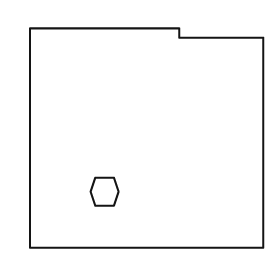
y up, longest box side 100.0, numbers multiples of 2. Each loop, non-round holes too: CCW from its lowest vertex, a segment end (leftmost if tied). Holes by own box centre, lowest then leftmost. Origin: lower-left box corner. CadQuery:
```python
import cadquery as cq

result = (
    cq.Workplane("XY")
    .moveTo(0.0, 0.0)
    .lineTo(100.0, 0.0)
    .lineTo(100.0, 90.0)
    .lineTo(64.0, 90.0)
    .lineTo(64.0, 94.0)
    .lineTo(0.0, 94.0)
    .close()
    .moveTo(28.0, 18.0)
    .lineTo(36.0, 18.0)
    .lineTo(38.0, 24.0)
    .lineTo(36.0, 30.0)
    .lineTo(28.0, 30.0)
    .lineTo(26.0, 24.0)
    .close()
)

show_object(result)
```